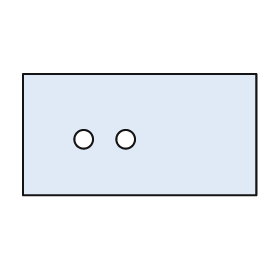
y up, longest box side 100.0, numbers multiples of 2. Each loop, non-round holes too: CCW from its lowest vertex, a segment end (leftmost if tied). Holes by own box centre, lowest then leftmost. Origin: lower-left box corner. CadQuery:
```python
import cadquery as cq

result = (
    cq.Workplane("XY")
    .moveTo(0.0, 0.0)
    .lineTo(100.0, 0.0)
    .lineTo(100.0, 52.0)
    .lineTo(0.0, 52.0)
    .close()
    .moveTo(26.0, 24.0)
    .circle(4.0)
    .moveTo(44.0, 24.0)
    .circle(4.0)
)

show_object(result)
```